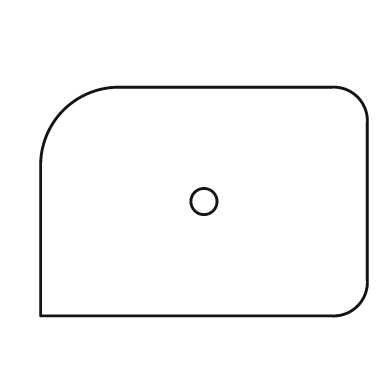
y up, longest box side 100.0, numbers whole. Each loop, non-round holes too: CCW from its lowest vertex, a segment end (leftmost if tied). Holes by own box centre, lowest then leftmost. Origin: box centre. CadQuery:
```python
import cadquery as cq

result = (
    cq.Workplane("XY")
    .moveTo(-50.0, -35.0)
    .lineTo(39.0, -35.0)
    .threePointArc((47.0, -32.0), (50.0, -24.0))
    .lineTo(50.0, 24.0)
    .threePointArc((47.0, 32.0), (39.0, 35.0))
    .lineTo(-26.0, 35.0)
    .threePointArc((-43.0, 28.0), (-50.0, 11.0))
    .close()
    .moveTo(0.0, 0.0)
    .circle(4.0)
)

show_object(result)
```